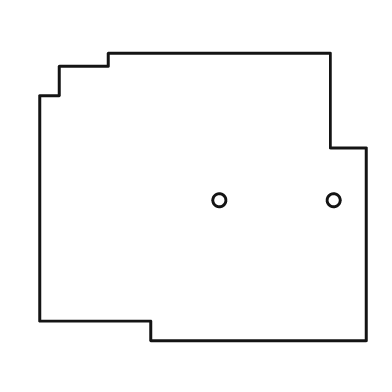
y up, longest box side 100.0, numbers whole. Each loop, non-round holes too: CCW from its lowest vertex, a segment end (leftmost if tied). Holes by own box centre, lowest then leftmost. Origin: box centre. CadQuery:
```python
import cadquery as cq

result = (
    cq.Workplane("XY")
    .moveTo(-16.0, -44.0)
    .lineTo(50.0, -44.0)
    .lineTo(50.0, 15.0)
    .lineTo(39.0, 15.0)
    .lineTo(39.0, 44.0)
    .lineTo(-29.0, 44.0)
    .lineTo(-29.0, 40.0)
    .lineTo(-44.0, 40.0)
    .lineTo(-44.0, 31.0)
    .lineTo(-50.0, 31.0)
    .lineTo(-50.0, -38.0)
    .lineTo(-16.0, -38.0)
    .close()
    .moveTo(5.0, -1.0)
    .circle(2.0)
    .moveTo(40.0, -1.0)
    .circle(2.0)
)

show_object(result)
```